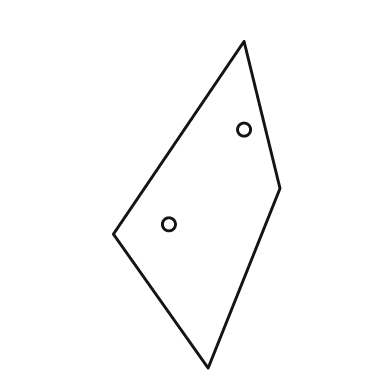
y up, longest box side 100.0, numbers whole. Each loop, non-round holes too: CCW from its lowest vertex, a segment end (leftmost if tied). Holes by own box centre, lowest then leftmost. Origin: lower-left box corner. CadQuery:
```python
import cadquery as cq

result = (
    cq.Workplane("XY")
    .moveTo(29.0, 0.0)
    .lineTo(51.0, 55.0)
    .lineTo(40.0, 100.0)
    .lineTo(0.0, 41.0)
    .close()
    .moveTo(17.0, 44.0)
    .circle(2.0)
    .moveTo(40.0, 73.0)
    .circle(2.0)
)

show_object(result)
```